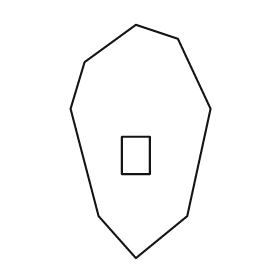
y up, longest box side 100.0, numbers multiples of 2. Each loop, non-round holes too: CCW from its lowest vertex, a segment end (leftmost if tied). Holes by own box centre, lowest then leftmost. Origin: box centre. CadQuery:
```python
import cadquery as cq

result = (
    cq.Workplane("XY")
    .moveTo(-2.0, -50.0)
    .lineTo(20.0, -32.0)
    .lineTo(30.0, 14.0)
    .lineTo(16.0, 44.0)
    .lineTo(-2.0, 50.0)
    .lineTo(-24.0, 34.0)
    .lineTo(-30.0, 14.0)
    .lineTo(-18.0, -32.0)
    .close()
    .moveTo(-8.0, -14.0)
    .lineTo(4.0, -14.0)
    .lineTo(4.0, 2.0)
    .lineTo(-8.0, 2.0)
    .close()
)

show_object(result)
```